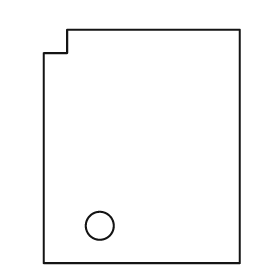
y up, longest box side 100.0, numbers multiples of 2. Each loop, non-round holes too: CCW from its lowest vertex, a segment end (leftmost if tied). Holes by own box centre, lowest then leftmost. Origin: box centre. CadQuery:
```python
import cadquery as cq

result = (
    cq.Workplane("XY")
    .moveTo(-42.0, -50.0)
    .lineTo(42.0, -50.0)
    .lineTo(42.0, 50.0)
    .lineTo(-32.0, 50.0)
    .lineTo(-32.0, 40.0)
    .lineTo(-42.0, 40.0)
    .close()
    .moveTo(-18.0, -34.0)
    .circle(6.0)
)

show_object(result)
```